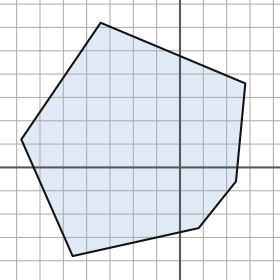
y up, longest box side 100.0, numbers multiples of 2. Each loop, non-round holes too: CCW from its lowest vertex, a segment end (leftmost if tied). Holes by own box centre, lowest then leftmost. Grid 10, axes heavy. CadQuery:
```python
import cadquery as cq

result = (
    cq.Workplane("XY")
    .moveTo(-46.0, -38.0)
    .lineTo(8.0, -26.0)
    .lineTo(24.0, -6.0)
    .lineTo(28.0, 36.0)
    .lineTo(-34.0, 62.0)
    .lineTo(-68.0, 12.0)
    .close()
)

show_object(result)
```